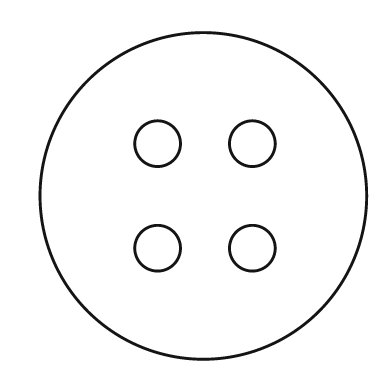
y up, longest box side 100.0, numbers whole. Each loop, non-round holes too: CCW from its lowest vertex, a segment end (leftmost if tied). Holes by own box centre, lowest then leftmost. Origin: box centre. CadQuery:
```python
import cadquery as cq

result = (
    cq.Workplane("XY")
    .moveTo(0.0, 0.0)
    .circle(50.0)
    .moveTo(-14.0, -16.0)
    .circle(7.0)
    .moveTo(15.0, -16.0)
    .circle(7.0)
    .moveTo(-14.0, 16.0)
    .circle(7.0)
    .moveTo(15.0, 16.0)
    .circle(7.0)
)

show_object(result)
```